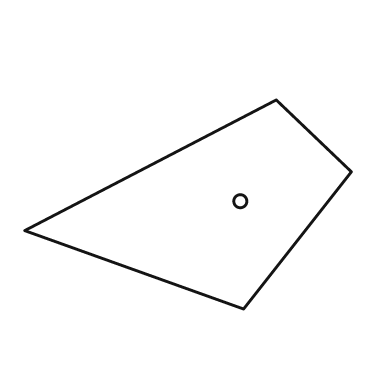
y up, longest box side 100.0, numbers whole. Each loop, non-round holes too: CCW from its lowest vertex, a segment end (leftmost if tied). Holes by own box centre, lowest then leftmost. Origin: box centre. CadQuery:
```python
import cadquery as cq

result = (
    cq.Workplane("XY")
    .moveTo(17.0, -32.0)
    .lineTo(50.0, 10.0)
    .lineTo(27.0, 32.0)
    .lineTo(-50.0, -8.0)
    .close()
    .moveTo(16.0, 1.0)
    .circle(2.0)
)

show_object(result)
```